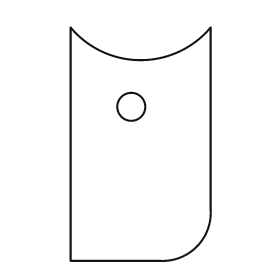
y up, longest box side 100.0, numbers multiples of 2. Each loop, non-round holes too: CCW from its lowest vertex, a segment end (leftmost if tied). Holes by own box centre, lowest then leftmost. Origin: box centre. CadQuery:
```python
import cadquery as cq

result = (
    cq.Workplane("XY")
    .moveTo(-30.0, -50.0)
    .lineTo(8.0, -50.0)
    .threePointArc((24.0, -44.0), (30.0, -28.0))
    .lineTo(30.0, 50.0)
    .threePointArc((0.0, 36.0), (-30.0, 50.0))
    .close()
    .moveTo(-4.0, 16.0)
    .circle(6.0)
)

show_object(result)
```